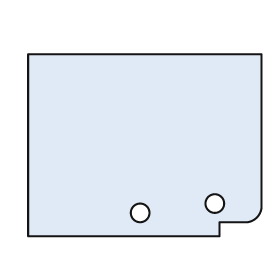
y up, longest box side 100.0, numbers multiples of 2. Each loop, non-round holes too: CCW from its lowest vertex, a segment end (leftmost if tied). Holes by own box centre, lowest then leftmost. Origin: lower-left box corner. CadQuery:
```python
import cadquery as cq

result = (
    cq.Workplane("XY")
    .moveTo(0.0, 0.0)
    .lineTo(82.0, 0.0)
    .lineTo(82.0, 6.0)
    .lineTo(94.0, 6.0)
    .threePointArc((98.0, 8.0), (100.0, 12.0))
    .lineTo(100.0, 78.0)
    .lineTo(0.0, 78.0)
    .close()
    .moveTo(48.0, 10.0)
    .circle(4.0)
    .moveTo(80.0, 14.0)
    .circle(4.0)
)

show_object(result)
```